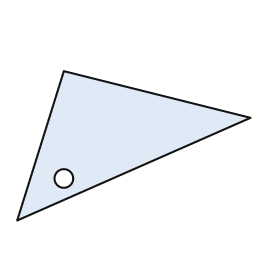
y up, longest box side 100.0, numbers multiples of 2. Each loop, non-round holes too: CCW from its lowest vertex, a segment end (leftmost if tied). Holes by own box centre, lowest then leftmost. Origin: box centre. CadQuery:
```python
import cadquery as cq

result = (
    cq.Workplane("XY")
    .moveTo(-50.0, -32.0)
    .lineTo(50.0, 12.0)
    .lineTo(-30.0, 32.0)
    .close()
    .moveTo(-30.0, -14.0)
    .circle(4.0)
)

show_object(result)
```